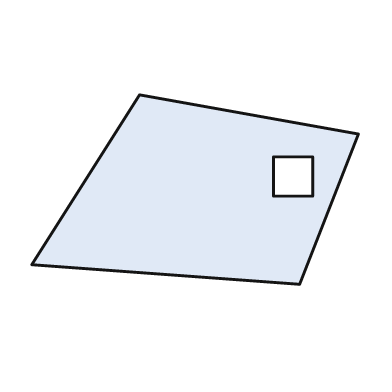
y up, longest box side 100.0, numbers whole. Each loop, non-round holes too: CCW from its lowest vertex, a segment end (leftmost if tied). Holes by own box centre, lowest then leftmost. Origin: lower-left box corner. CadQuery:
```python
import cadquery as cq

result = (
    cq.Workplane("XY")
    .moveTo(82.0, 0.0)
    .lineTo(100.0, 46.0)
    .lineTo(33.0, 58.0)
    .lineTo(0.0, 6.0)
    .close()
    .moveTo(74.0, 27.0)
    .lineTo(86.0, 27.0)
    .lineTo(86.0, 39.0)
    .lineTo(74.0, 39.0)
    .close()
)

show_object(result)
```